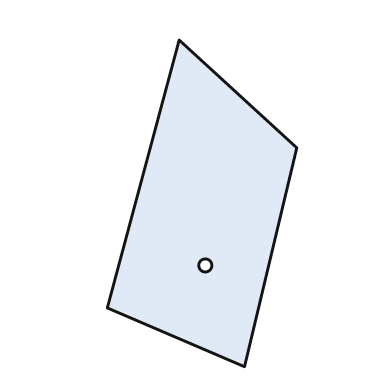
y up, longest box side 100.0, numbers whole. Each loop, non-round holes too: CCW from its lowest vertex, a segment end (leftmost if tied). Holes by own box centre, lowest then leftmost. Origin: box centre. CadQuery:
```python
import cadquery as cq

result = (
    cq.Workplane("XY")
    .moveTo(13.0, -50.0)
    .lineTo(29.0, 17.0)
    .lineTo(-7.0, 50.0)
    .lineTo(-29.0, -32.0)
    .close()
    .moveTo(1.0, -19.0)
    .circle(2.0)
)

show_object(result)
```